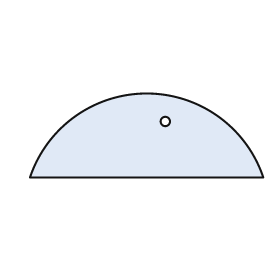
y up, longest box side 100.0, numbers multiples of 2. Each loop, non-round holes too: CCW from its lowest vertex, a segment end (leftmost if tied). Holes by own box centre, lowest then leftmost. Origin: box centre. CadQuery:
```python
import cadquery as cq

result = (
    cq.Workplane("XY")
    .moveTo(-50.0, -18.0)
    .lineTo(50.0, -18.0)
    .threePointArc((0.0, 18.0), (-50.0, -18.0))
    .close()
    .moveTo(8.0, 6.0)
    .circle(2.0)
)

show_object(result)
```